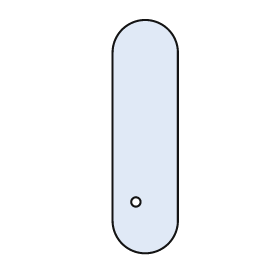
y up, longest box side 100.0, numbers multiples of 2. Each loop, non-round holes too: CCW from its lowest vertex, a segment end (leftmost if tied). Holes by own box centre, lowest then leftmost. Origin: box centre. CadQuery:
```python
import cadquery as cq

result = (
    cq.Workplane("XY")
    .moveTo(-14.0, -36.0)
    .threePointArc((0.0, -50.0), (14.0, -36.0))
    .lineTo(14.0, 36.0)
    .threePointArc((0.0, 50.0), (-14.0, 36.0))
    .close()
    .moveTo(-4.0, -28.0)
    .circle(2.0)
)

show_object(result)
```